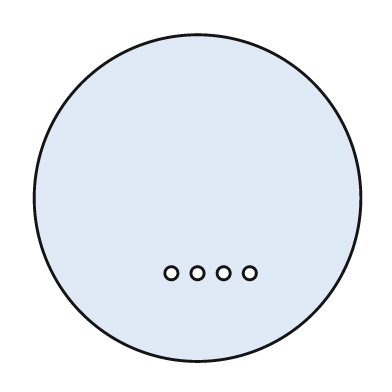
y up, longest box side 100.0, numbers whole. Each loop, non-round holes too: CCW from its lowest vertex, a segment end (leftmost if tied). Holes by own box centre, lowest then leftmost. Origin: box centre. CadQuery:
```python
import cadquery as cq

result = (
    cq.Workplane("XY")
    .moveTo(0.0, 0.0)
    .circle(50.0)
    .moveTo(-8.0, -23.0)
    .circle(2.0)
    .moveTo(0.0, -23.0)
    .circle(2.0)
    .moveTo(8.0, -23.0)
    .circle(2.0)
    .moveTo(16.0, -23.0)
    .circle(2.0)
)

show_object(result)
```